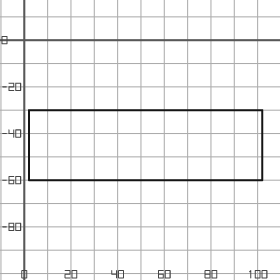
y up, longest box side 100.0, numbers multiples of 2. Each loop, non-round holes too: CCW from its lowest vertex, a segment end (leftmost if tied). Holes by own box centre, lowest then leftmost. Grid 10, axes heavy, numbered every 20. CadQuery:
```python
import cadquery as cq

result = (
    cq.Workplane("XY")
    .moveTo(2.0, -60.0)
    .lineTo(102.0, -60.0)
    .lineTo(102.0, -30.0)
    .lineTo(2.0, -30.0)
    .close()
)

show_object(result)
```